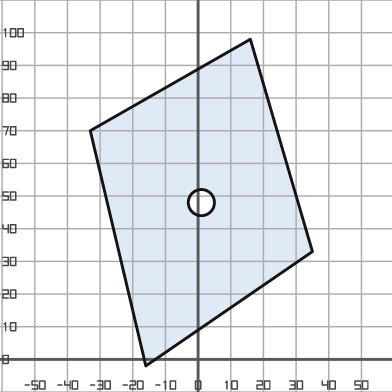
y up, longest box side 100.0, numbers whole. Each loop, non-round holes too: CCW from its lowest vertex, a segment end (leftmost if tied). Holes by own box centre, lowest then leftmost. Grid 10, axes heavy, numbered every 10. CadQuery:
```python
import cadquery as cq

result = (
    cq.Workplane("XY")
    .moveTo(-16.0, -2.0)
    .lineTo(35.0, 33.0)
    .lineTo(16.0, 98.0)
    .lineTo(-33.0, 70.0)
    .close()
    .moveTo(1.0, 48.0)
    .circle(4.0)
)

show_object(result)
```